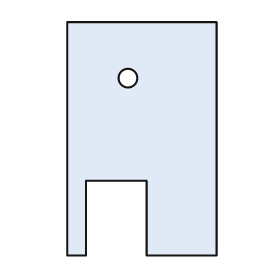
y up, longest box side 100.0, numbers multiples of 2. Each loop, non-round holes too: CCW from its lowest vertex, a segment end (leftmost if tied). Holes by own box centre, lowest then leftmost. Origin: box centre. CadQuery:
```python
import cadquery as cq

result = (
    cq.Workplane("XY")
    .moveTo(-32.0, -50.0)
    .lineTo(-24.0, -50.0)
    .lineTo(-24.0, -18.0)
    .lineTo(2.0, -18.0)
    .lineTo(2.0, -50.0)
    .lineTo(32.0, -50.0)
    .lineTo(32.0, 50.0)
    .lineTo(-32.0, 50.0)
    .close()
    .moveTo(-6.0, 26.0)
    .circle(4.0)
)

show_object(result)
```